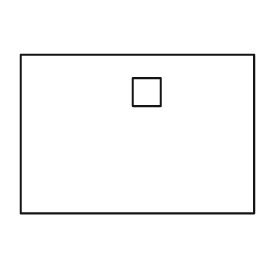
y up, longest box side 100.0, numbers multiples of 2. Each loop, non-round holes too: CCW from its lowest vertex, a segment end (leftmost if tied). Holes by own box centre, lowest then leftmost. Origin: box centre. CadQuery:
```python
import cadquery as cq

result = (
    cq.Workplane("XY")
    .moveTo(-50.0, -34.0)
    .lineTo(50.0, -34.0)
    .lineTo(50.0, 34.0)
    .lineTo(-50.0, 34.0)
    .close()
    .moveTo(-2.0, 12.0)
    .lineTo(10.0, 12.0)
    .lineTo(10.0, 24.0)
    .lineTo(-2.0, 24.0)
    .close()
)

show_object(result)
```